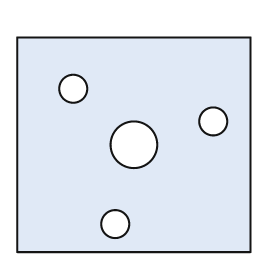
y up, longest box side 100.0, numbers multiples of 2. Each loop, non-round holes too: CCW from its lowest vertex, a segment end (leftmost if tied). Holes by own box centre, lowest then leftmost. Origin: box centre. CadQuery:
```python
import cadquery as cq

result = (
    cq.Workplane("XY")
    .moveTo(-50.0, -46.0)
    .lineTo(50.0, -46.0)
    .lineTo(50.0, 46.0)
    .lineTo(-50.0, 46.0)
    .close()
    .moveTo(-8.0, -34.0)
    .circle(6.0)
    .moveTo(0.0, 0.0)
    .circle(10.0)
    .moveTo(34.0, 10.0)
    .circle(6.0)
    .moveTo(-26.0, 24.0)
    .circle(6.0)
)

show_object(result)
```